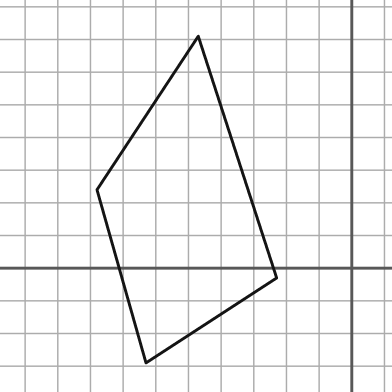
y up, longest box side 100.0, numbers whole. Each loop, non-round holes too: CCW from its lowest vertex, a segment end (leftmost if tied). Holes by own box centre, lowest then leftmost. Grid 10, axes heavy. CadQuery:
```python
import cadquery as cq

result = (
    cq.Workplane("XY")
    .moveTo(-63.0, -29.0)
    .lineTo(-23.0, -3.0)
    .lineTo(-47.0, 71.0)
    .lineTo(-78.0, 24.0)
    .close()
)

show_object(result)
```